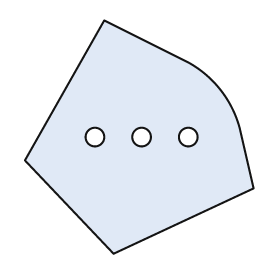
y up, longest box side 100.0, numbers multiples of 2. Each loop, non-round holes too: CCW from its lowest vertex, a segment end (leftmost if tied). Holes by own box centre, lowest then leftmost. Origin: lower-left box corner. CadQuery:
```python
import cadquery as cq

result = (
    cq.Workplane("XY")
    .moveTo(38.0, 0.0)
    .lineTo(98.0, 28.0)
    .lineTo(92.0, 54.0)
    .threePointArc((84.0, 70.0), (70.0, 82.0))
    .lineTo(34.0, 100.0)
    .lineTo(0.0, 40.0)
    .close()
    .moveTo(30.0, 50.0)
    .circle(4.0)
    .moveTo(50.0, 50.0)
    .circle(4.0)
    .moveTo(70.0, 50.0)
    .circle(4.0)
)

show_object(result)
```